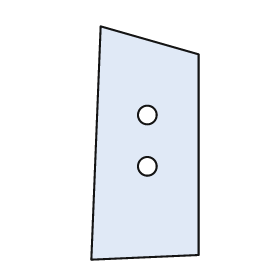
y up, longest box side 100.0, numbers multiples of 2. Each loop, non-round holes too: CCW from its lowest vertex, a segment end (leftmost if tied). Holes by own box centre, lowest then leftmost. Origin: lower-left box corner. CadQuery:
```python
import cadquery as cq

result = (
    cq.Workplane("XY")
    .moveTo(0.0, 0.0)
    .lineTo(46.0, 2.0)
    .lineTo(46.0, 88.0)
    .lineTo(4.0, 100.0)
    .close()
    .moveTo(24.0, 40.0)
    .circle(4.0)
    .moveTo(24.0, 62.0)
    .circle(4.0)
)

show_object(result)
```